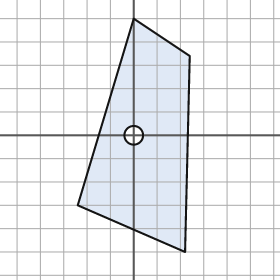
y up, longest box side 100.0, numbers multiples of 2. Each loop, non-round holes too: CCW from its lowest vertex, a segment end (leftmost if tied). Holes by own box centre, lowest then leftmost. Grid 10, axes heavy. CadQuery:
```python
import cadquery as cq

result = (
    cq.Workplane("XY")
    .moveTo(22.0, -50.0)
    .lineTo(24.0, 34.0)
    .lineTo(0.0, 50.0)
    .lineTo(-24.0, -30.0)
    .close()
    .moveTo(0.0, 0.0)
    .circle(4.0)
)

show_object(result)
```